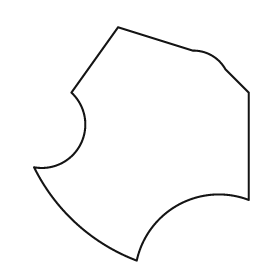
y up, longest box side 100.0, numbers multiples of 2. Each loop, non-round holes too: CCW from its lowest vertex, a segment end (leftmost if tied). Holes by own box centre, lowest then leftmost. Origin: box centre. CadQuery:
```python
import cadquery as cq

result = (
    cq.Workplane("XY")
    .moveTo(-2.0, -50.0)
    .threePointArc((16.0, -26.0), (46.0, -24.0))
    .lineTo(46.0, 22.0)
    .lineTo(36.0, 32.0)
    .threePointArc((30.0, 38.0), (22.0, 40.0))
    .lineTo(-10.0, 50.0)
    .lineTo(-30.0, 22.0)
    .threePointArc((-26.0, 0.0), (-46.0, -10.0))
    .threePointArc((-28.0, -34.0), (-2.0, -50.0))
    .close()
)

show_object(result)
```